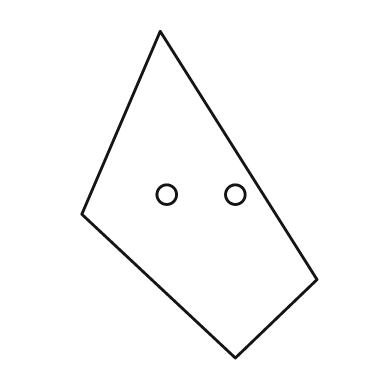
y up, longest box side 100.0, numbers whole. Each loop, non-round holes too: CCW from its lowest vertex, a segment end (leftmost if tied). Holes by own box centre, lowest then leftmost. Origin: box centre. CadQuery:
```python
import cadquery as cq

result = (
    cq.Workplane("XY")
    .moveTo(11.0, -50.0)
    .lineTo(36.0, -26.0)
    .lineTo(-12.0, 50.0)
    .lineTo(-36.0, -6.0)
    .close()
    .moveTo(-10.0, 0.0)
    .circle(3.0)
    .moveTo(11.0, 0.0)
    .circle(3.0)
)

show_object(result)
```